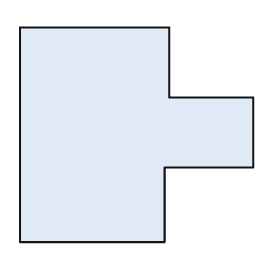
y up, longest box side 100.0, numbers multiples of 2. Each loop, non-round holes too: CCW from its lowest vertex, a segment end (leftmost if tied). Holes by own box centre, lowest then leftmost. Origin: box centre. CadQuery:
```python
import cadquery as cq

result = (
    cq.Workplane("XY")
    .moveTo(-50.0, -46.0)
    .lineTo(12.0, -46.0)
    .lineTo(12.0, -14.0)
    .lineTo(50.0, -14.0)
    .lineTo(50.0, 16.0)
    .lineTo(14.0, 16.0)
    .lineTo(14.0, 46.0)
    .lineTo(-50.0, 46.0)
    .close()
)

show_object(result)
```